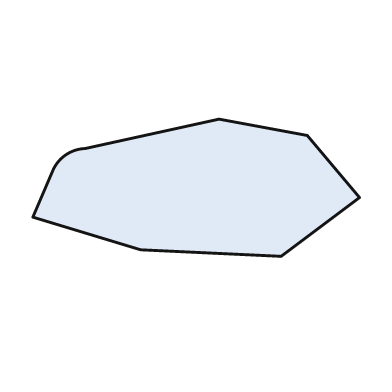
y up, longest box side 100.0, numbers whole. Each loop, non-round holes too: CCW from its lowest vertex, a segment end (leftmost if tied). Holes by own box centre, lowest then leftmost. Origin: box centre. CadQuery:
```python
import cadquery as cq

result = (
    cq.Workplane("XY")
    .moveTo(26.0, -21.0)
    .lineTo(50.0, -3.0)
    .lineTo(34.0, 16.0)
    .lineTo(7.0, 21.0)
    .lineTo(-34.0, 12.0)
    .threePointArc((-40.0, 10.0), (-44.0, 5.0))
    .lineTo(-50.0, -9.0)
    .lineTo(-17.0, -19.0)
    .close()
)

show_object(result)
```